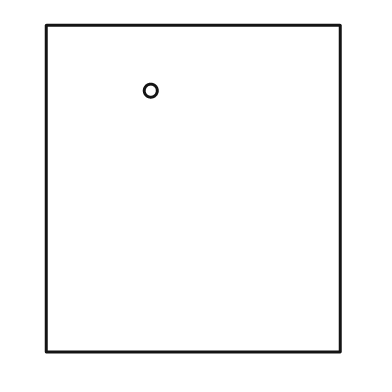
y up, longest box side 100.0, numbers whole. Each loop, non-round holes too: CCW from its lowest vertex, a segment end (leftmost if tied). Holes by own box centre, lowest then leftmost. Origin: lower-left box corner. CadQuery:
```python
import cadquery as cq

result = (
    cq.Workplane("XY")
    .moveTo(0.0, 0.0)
    .lineTo(90.0, 0.0)
    .lineTo(90.0, 100.0)
    .lineTo(0.0, 100.0)
    .close()
    .moveTo(32.0, 80.0)
    .circle(2.0)
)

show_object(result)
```